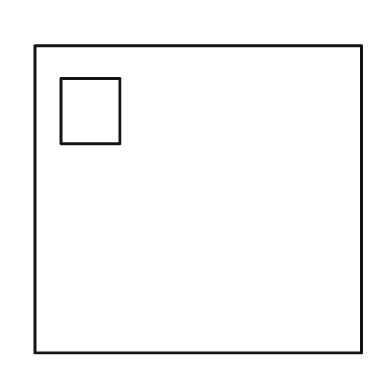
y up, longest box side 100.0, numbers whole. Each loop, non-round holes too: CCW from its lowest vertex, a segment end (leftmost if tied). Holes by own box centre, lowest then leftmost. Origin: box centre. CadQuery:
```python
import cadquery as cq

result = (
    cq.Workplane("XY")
    .moveTo(-50.0, -47.0)
    .lineTo(50.0, -47.0)
    .lineTo(50.0, 47.0)
    .lineTo(-50.0, 47.0)
    .close()
    .moveTo(-42.0, 17.0)
    .lineTo(-24.0, 17.0)
    .lineTo(-24.0, 37.0)
    .lineTo(-42.0, 37.0)
    .close()
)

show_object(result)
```